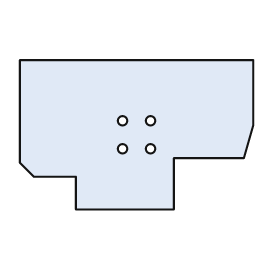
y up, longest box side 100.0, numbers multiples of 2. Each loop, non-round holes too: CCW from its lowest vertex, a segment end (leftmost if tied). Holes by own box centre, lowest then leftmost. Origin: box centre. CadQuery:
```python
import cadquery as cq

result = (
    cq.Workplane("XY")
    .moveTo(-26.0, -32.0)
    .lineTo(16.0, -32.0)
    .lineTo(16.0, -10.0)
    .lineTo(46.0, -10.0)
    .lineTo(50.0, 4.0)
    .lineTo(50.0, 32.0)
    .lineTo(-50.0, 32.0)
    .lineTo(-50.0, -12.0)
    .lineTo(-44.0, -18.0)
    .lineTo(-26.0, -18.0)
    .close()
    .moveTo(-6.0, -6.0)
    .circle(2.0)
    .moveTo(6.0, -6.0)
    .circle(2.0)
    .moveTo(-6.0, 6.0)
    .circle(2.0)
    .moveTo(6.0, 6.0)
    .circle(2.0)
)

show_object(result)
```